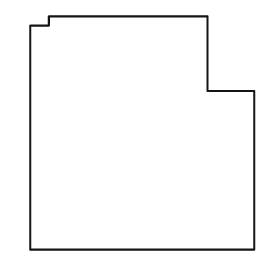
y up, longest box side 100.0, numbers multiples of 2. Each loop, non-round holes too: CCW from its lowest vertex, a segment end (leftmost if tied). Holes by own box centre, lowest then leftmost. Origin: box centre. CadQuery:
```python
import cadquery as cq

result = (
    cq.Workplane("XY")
    .moveTo(-48.0, -50.0)
    .lineTo(48.0, -50.0)
    .lineTo(48.0, 18.0)
    .lineTo(28.0, 18.0)
    .lineTo(28.0, 50.0)
    .lineTo(-40.0, 50.0)
    .lineTo(-40.0, 46.0)
    .lineTo(-48.0, 46.0)
    .close()
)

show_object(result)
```